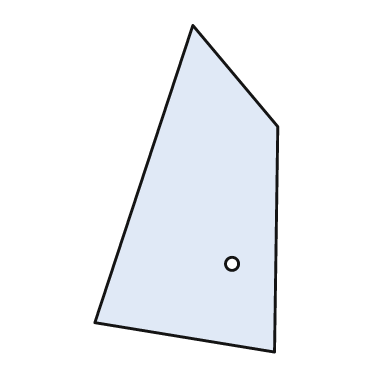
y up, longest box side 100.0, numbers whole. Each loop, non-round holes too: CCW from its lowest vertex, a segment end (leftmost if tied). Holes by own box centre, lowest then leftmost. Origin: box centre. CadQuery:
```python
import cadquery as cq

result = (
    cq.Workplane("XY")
    .moveTo(27.0, -50.0)
    .lineTo(28.0, 19.0)
    .lineTo(2.0, 50.0)
    .lineTo(-28.0, -41.0)
    .close()
    .moveTo(14.0, -23.0)
    .circle(2.0)
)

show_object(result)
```